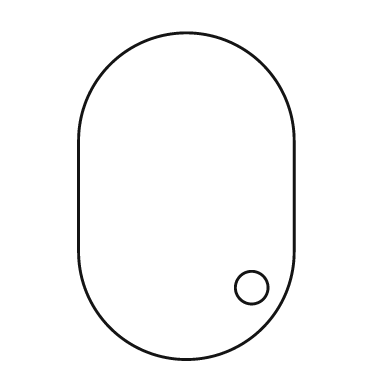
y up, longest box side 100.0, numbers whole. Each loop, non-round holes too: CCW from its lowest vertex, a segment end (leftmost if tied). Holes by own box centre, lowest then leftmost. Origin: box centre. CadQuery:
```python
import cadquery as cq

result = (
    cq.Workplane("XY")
    .moveTo(-33.0, -17.0)
    .threePointArc((0.0, -50.0), (33.0, -17.0))
    .lineTo(33.0, 17.0)
    .threePointArc((0.0, 50.0), (-33.0, 17.0))
    .close()
    .moveTo(20.0, -28.0)
    .circle(5.0)
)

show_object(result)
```